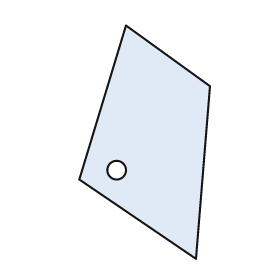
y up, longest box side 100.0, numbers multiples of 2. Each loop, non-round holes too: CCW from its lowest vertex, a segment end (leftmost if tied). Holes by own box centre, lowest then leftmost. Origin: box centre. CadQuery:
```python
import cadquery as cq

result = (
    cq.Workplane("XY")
    .moveTo(22.0, -50.0)
    .lineTo(28.0, 24.0)
    .lineTo(-8.0, 50.0)
    .lineTo(-28.0, -16.0)
    .close()
    .moveTo(-12.0, -12.0)
    .circle(4.0)
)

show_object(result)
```